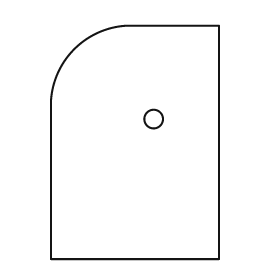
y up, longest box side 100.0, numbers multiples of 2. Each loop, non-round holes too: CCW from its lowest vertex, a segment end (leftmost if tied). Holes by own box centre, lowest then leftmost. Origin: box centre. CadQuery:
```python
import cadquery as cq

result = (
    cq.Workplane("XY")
    .moveTo(-36.0, -50.0)
    .lineTo(36.0, -50.0)
    .lineTo(36.0, 50.0)
    .lineTo(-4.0, 50.0)
    .threePointArc((-26.0, 40.0), (-36.0, 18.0))
    .close()
    .moveTo(8.0, 10.0)
    .circle(4.0)
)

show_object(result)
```